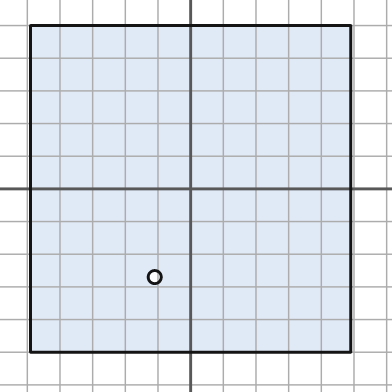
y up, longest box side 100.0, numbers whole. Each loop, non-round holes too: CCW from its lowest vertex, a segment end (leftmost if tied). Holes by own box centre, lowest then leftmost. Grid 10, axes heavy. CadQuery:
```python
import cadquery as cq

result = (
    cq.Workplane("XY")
    .moveTo(-49.0, -50.0)
    .lineTo(49.0, -50.0)
    .lineTo(49.0, 50.0)
    .lineTo(-49.0, 50.0)
    .close()
    .moveTo(-11.0, -27.0)
    .circle(2.0)
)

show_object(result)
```